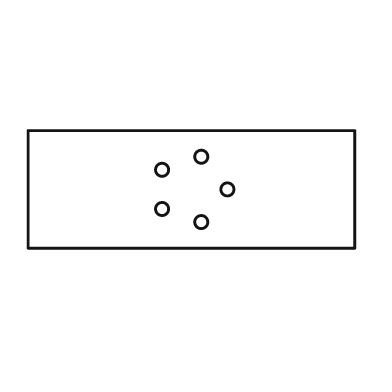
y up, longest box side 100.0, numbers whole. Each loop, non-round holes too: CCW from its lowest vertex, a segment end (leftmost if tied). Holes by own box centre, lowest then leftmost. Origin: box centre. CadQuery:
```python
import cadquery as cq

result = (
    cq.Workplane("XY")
    .moveTo(-50.0, -18.0)
    .lineTo(50.0, -18.0)
    .lineTo(50.0, 18.0)
    .lineTo(-50.0, 18.0)
    .close()
    .moveTo(3.0, -10.0)
    .circle(2.0)
    .moveTo(-9.0, -6.0)
    .circle(2.0)
    .moveTo(11.0, 0.0)
    .circle(2.0)
    .moveTo(-9.0, 6.0)
    .circle(2.0)
    .moveTo(3.0, 10.0)
    .circle(2.0)
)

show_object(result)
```